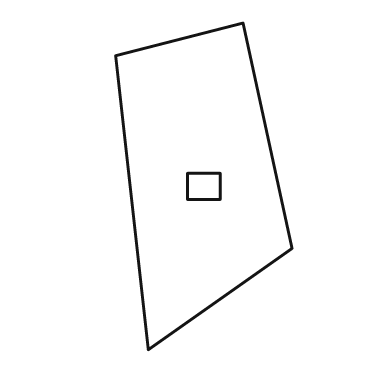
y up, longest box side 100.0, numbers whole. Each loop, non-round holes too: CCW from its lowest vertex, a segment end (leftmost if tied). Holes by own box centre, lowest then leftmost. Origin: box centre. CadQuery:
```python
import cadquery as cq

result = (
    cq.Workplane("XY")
    .moveTo(-17.0, -50.0)
    .lineTo(27.0, -19.0)
    .lineTo(12.0, 50.0)
    .lineTo(-27.0, 40.0)
    .close()
    .moveTo(-5.0, -4.0)
    .lineTo(5.0, -4.0)
    .lineTo(5.0, 4.0)
    .lineTo(-5.0, 4.0)
    .close()
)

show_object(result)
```